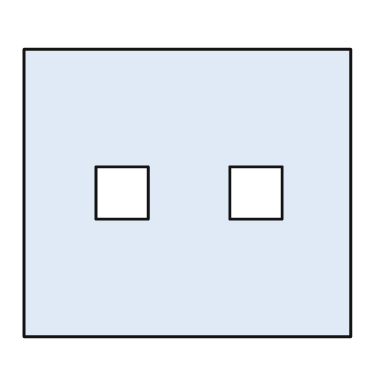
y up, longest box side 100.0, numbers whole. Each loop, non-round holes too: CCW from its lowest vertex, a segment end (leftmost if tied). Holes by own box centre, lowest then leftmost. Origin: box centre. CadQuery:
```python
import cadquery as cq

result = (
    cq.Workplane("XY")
    .moveTo(-50.0, -44.0)
    .lineTo(50.0, -44.0)
    .lineTo(50.0, 44.0)
    .lineTo(-50.0, 44.0)
    .close()
    .moveTo(-28.0, -8.0)
    .lineTo(-12.0, -8.0)
    .lineTo(-12.0, 8.0)
    .lineTo(-28.0, 8.0)
    .close()
    .moveTo(13.0, -8.0)
    .lineTo(29.0, -8.0)
    .lineTo(29.0, 8.0)
    .lineTo(13.0, 8.0)
    .close()
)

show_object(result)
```